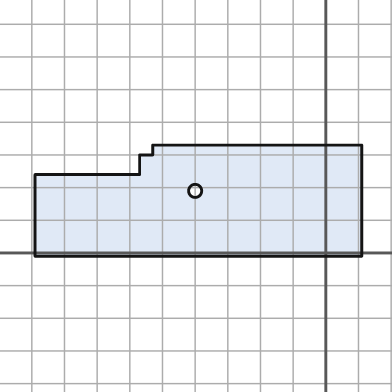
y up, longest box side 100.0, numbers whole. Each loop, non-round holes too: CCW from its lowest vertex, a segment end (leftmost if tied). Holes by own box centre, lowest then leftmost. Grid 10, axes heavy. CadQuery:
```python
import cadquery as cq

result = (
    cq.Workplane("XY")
    .moveTo(-89.0, -1.0)
    .lineTo(11.0, -1.0)
    .lineTo(11.0, 33.0)
    .lineTo(-53.0, 33.0)
    .lineTo(-53.0, 30.0)
    .lineTo(-57.0, 30.0)
    .lineTo(-57.0, 24.0)
    .lineTo(-89.0, 24.0)
    .close()
    .moveTo(-40.0, 19.0)
    .circle(2.0)
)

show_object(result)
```